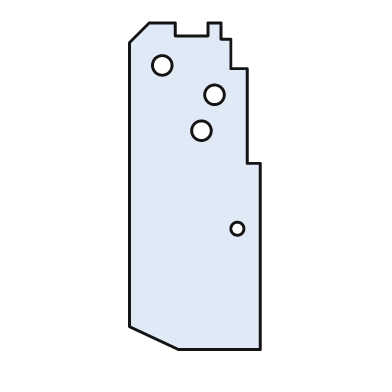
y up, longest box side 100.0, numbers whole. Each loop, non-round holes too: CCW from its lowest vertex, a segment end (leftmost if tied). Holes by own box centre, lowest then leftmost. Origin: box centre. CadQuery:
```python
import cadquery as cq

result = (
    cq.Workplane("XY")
    .moveTo(-5.0, -50.0)
    .lineTo(20.0, -50.0)
    .lineTo(20.0, 7.0)
    .lineTo(16.0, 7.0)
    .lineTo(16.0, 36.0)
    .lineTo(11.0, 36.0)
    .lineTo(11.0, 45.0)
    .lineTo(8.0, 45.0)
    .lineTo(8.0, 50.0)
    .lineTo(4.0, 50.0)
    .lineTo(4.0, 46.0)
    .lineTo(-6.0, 46.0)
    .lineTo(-6.0, 50.0)
    .lineTo(-14.0, 50.0)
    .lineTo(-20.0, 44.0)
    .lineTo(-20.0, -43.0)
    .close()
    .moveTo(13.0, -13.0)
    .circle(2.0)
    .moveTo(2.0, 17.0)
    .circle(3.0)
    .moveTo(6.0, 28.0)
    .circle(3.0)
    .moveTo(-10.0, 37.0)
    .circle(3.0)
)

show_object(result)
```